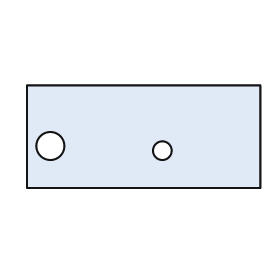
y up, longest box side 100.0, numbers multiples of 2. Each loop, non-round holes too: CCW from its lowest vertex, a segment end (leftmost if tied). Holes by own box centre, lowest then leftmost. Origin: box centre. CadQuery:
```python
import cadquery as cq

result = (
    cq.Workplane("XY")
    .moveTo(-50.0, -22.0)
    .lineTo(50.0, -22.0)
    .lineTo(50.0, 22.0)
    .lineTo(-50.0, 22.0)
    .close()
    .moveTo(8.0, -6.0)
    .circle(4.0)
    .moveTo(-40.0, -4.0)
    .circle(6.0)
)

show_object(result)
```